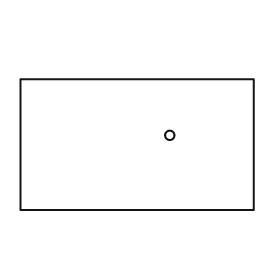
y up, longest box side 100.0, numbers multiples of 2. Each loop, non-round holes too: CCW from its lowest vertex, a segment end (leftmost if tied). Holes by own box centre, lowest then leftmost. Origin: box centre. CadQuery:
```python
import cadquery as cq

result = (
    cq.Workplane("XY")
    .moveTo(-50.0, -28.0)
    .lineTo(50.0, -28.0)
    .lineTo(50.0, 28.0)
    .lineTo(-50.0, 28.0)
    .close()
    .moveTo(14.0, 4.0)
    .circle(2.0)
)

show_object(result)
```